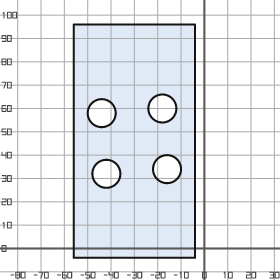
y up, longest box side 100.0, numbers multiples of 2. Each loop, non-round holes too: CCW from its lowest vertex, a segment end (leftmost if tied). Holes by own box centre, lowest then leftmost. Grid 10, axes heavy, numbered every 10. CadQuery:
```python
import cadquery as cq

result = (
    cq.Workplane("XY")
    .moveTo(-56.0, -4.0)
    .lineTo(-4.0, -4.0)
    .lineTo(-4.0, 96.0)
    .lineTo(-56.0, 96.0)
    .close()
    .moveTo(-42.0, 32.0)
    .circle(6.0)
    .moveTo(-16.0, 34.0)
    .circle(6.0)
    .moveTo(-44.0, 58.0)
    .circle(6.0)
    .moveTo(-18.0, 60.0)
    .circle(6.0)
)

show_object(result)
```